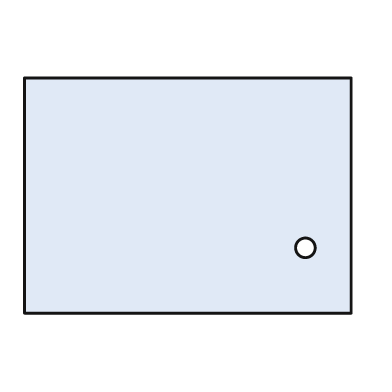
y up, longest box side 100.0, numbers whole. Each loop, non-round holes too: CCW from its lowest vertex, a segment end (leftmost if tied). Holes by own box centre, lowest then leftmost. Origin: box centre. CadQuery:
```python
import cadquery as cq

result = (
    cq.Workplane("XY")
    .moveTo(-50.0, -36.0)
    .lineTo(50.0, -36.0)
    .lineTo(50.0, 36.0)
    .lineTo(-50.0, 36.0)
    .close()
    .moveTo(36.0, -16.0)
    .circle(3.0)
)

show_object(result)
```